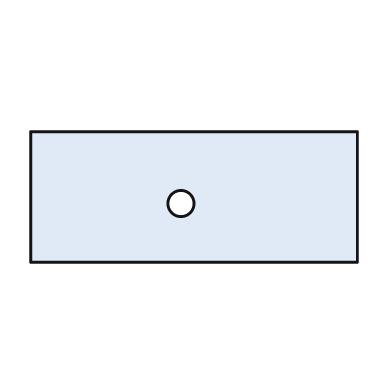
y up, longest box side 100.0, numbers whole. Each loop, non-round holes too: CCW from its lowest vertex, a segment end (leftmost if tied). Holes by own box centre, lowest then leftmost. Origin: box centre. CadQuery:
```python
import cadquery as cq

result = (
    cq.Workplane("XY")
    .moveTo(-50.0, -20.0)
    .lineTo(50.0, -20.0)
    .lineTo(50.0, 20.0)
    .lineTo(-50.0, 20.0)
    .close()
    .moveTo(-4.0, -2.0)
    .circle(4.0)
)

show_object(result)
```